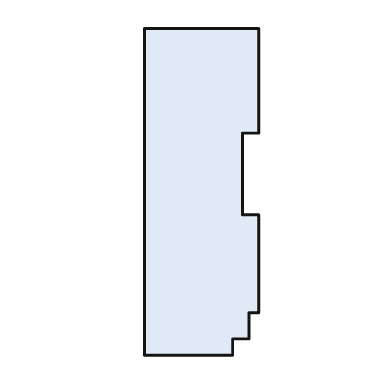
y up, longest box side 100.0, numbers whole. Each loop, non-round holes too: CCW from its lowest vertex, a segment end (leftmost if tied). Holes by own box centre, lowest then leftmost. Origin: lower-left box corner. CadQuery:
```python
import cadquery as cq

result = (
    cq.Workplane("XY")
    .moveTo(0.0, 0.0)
    .lineTo(27.0, 0.0)
    .lineTo(27.0, 5.0)
    .lineTo(32.0, 5.0)
    .lineTo(32.0, 13.0)
    .lineTo(35.0, 13.0)
    .lineTo(35.0, 43.0)
    .lineTo(30.0, 43.0)
    .lineTo(30.0, 68.0)
    .lineTo(35.0, 68.0)
    .lineTo(35.0, 100.0)
    .lineTo(0.0, 100.0)
    .close()
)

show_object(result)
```